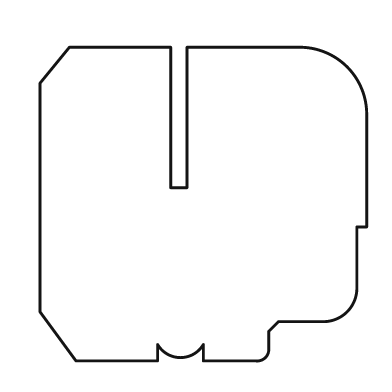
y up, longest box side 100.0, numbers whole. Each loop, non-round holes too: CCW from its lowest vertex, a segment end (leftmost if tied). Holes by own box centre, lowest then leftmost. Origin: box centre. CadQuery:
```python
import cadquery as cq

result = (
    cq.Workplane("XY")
    .moveTo(-39.0, -48.0)
    .lineTo(-14.0, -48.0)
    .lineTo(-14.0, -43.0)
    .threePointArc((-7.0, -47.0), (0.0, -43.0))
    .lineTo(0.0, -48.0)
    .lineTo(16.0, -48.0)
    .threePointArc((19.0, -47.0), (20.0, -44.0))
    .lineTo(20.0, -39.0)
    .lineTo(23.0, -36.0)
    .lineTo(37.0, -36.0)
    .threePointArc((44.0, -33.0), (47.0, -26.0))
    .lineTo(47.0, -7.0)
    .lineTo(50.0, -7.0)
    .lineTo(50.0, 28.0)
    .threePointArc((44.0, 42.0), (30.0, 48.0))
    .lineTo(-5.0, 48.0)
    .lineTo(-5.0, 5.0)
    .lineTo(-10.0, 5.0)
    .lineTo(-10.0, 48.0)
    .lineTo(-41.0, 48.0)
    .lineTo(-50.0, 37.0)
    .lineTo(-50.0, -33.0)
    .close()
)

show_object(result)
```